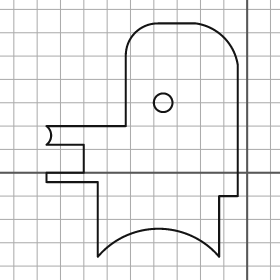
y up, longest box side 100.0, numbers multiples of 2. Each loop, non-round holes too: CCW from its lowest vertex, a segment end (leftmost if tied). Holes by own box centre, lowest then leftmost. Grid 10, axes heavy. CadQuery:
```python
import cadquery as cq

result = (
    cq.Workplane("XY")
    .moveTo(-64.0, -36.0)
    .threePointArc((-38.0, -24.0), (-12.0, -36.0))
    .lineTo(-12.0, -10.0)
    .lineTo(-4.0, -10.0)
    .lineTo(-4.0, 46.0)
    .threePointArc((-10.0, 58.0), (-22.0, 64.0))
    .lineTo(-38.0, 64.0)
    .threePointArc((-48.0, 60.0), (-52.0, 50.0))
    .lineTo(-52.0, 20.0)
    .lineTo(-86.0, 20.0)
    .threePointArc((-84.0, 16.0), (-86.0, 12.0))
    .lineTo(-70.0, 12.0)
    .lineTo(-70.0, 0.0)
    .lineTo(-86.0, 0.0)
    .lineTo(-86.0, -4.0)
    .lineTo(-64.0, -4.0)
    .close()
    .moveTo(-36.0, 30.0)
    .circle(4.0)
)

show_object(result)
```